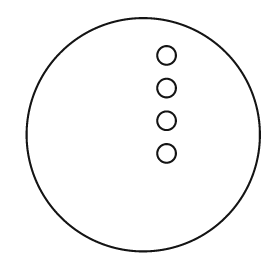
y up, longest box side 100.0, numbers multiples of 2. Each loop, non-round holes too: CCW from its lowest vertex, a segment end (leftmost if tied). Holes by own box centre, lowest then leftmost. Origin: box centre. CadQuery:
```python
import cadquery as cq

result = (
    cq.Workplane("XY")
    .moveTo(0.0, 0.0)
    .circle(50.0)
    .moveTo(10.0, -8.0)
    .circle(4.0)
    .moveTo(10.0, 6.0)
    .circle(4.0)
    .moveTo(10.0, 20.0)
    .circle(4.0)
    .moveTo(10.0, 34.0)
    .circle(4.0)
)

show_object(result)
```